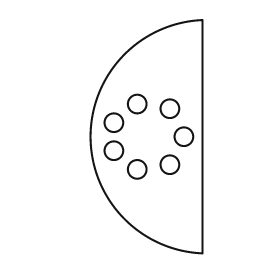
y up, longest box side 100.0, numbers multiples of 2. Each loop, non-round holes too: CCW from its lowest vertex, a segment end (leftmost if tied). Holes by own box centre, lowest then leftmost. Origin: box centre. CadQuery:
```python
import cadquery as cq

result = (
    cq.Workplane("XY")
    .moveTo(24.0, -50.0)
    .lineTo(24.0, 50.0)
    .threePointArc((-24.0, 0.0), (24.0, -50.0))
    .close()
    .moveTo(-4.0, -14.0)
    .circle(4.0)
    .moveTo(10.0, -12.0)
    .circle(4.0)
    .moveTo(-14.0, -6.0)
    .circle(4.0)
    .moveTo(16.0, 0.0)
    .circle(4.0)
    .moveTo(-14.0, 6.0)
    .circle(4.0)
    .moveTo(10.0, 12.0)
    .circle(4.0)
    .moveTo(-4.0, 14.0)
    .circle(4.0)
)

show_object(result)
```